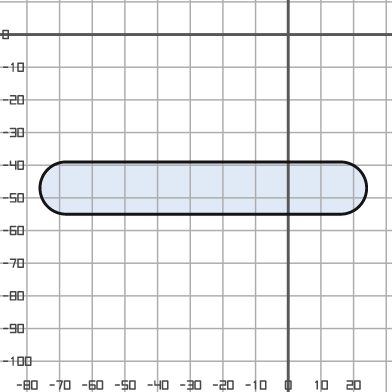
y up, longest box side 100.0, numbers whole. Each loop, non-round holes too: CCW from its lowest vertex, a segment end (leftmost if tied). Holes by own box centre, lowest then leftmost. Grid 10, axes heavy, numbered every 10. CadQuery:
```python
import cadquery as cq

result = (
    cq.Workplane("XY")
    .moveTo(-68.0, -55.0)
    .lineTo(16.0, -55.0)
    .threePointArc((24.0, -47.0), (16.0, -39.0))
    .lineTo(-68.0, -39.0)
    .threePointArc((-76.0, -47.0), (-68.0, -55.0))
    .close()
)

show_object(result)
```